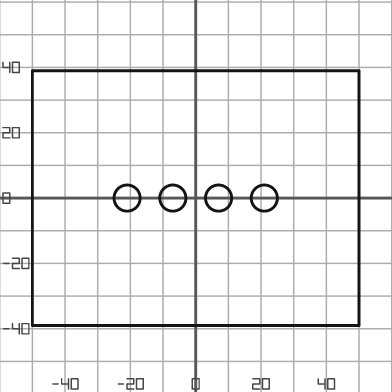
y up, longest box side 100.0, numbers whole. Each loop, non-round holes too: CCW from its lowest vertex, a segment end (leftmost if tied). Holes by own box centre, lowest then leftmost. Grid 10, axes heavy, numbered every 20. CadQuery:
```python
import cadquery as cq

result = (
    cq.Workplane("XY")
    .moveTo(-50.0, -39.0)
    .lineTo(50.0, -39.0)
    .lineTo(50.0, 39.0)
    .lineTo(-50.0, 39.0)
    .close()
    .moveTo(-21.0, 0.0)
    .circle(4.0)
    .moveTo(-7.0, 0.0)
    .circle(4.0)
    .moveTo(7.0, 0.0)
    .circle(4.0)
    .moveTo(21.0, 0.0)
    .circle(4.0)
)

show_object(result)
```